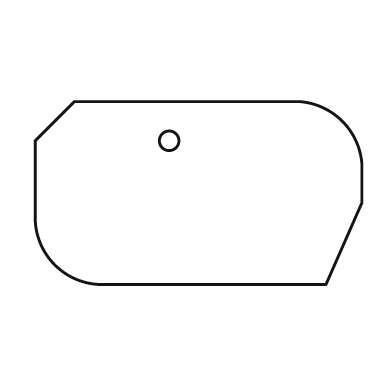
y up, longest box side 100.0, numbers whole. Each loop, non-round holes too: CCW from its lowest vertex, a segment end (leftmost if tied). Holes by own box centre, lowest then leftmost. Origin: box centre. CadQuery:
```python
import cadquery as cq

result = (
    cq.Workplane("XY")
    .moveTo(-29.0, -28.0)
    .lineTo(39.0, -28.0)
    .lineTo(50.0, -3.0)
    .lineTo(50.0, 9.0)
    .threePointArc((44.0, 22.0), (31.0, 28.0))
    .lineTo(-38.0, 28.0)
    .lineTo(-50.0, 16.0)
    .lineTo(-50.0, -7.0)
    .threePointArc((-44.0, -22.0), (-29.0, -28.0))
    .close()
    .moveTo(-9.0, 16.0)
    .circle(3.0)
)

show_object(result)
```